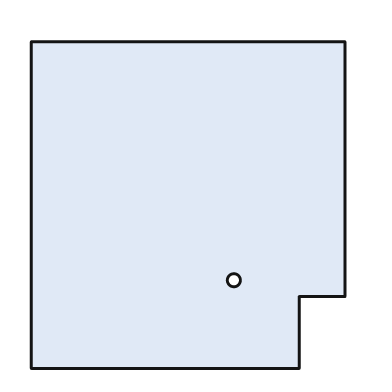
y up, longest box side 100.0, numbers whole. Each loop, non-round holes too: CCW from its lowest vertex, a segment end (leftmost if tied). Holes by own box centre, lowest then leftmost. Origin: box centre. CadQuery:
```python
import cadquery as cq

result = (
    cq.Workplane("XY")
    .moveTo(-48.0, -50.0)
    .lineTo(34.0, -50.0)
    .lineTo(34.0, -28.0)
    .lineTo(48.0, -28.0)
    .lineTo(48.0, 50.0)
    .lineTo(-48.0, 50.0)
    .close()
    .moveTo(14.0, -23.0)
    .circle(2.0)
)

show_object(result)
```